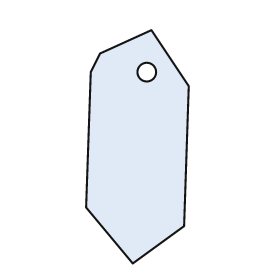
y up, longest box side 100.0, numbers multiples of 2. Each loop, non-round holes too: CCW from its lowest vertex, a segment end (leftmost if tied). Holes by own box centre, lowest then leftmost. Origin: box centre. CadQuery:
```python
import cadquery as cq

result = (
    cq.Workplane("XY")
    .moveTo(-2.0, -50.0)
    .lineTo(20.0, -34.0)
    .lineTo(22.0, 26.0)
    .lineTo(6.0, 50.0)
    .lineTo(-16.0, 40.0)
    .lineTo(-20.0, 32.0)
    .lineTo(-22.0, -26.0)
    .close()
    .moveTo(4.0, 32.0)
    .circle(4.0)
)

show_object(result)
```